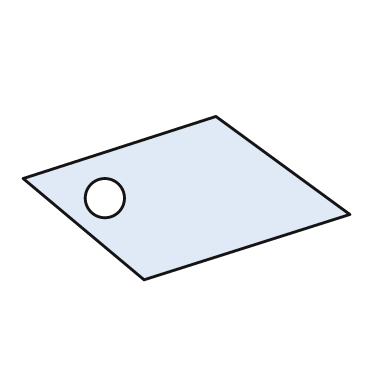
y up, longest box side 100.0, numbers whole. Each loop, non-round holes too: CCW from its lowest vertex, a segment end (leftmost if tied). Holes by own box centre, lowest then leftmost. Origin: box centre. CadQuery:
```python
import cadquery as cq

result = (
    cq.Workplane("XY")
    .moveTo(-13.0, -25.0)
    .lineTo(50.0, -5.0)
    .lineTo(9.0, 25.0)
    .lineTo(-50.0, 6.0)
    .close()
    .moveTo(-25.0, 0.0)
    .circle(6.0)
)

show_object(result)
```